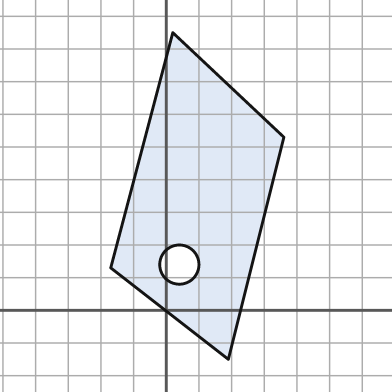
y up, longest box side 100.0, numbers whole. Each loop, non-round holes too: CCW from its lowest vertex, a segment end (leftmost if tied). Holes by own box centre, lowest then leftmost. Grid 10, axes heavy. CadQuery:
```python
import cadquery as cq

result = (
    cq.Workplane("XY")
    .moveTo(19.0, -15.0)
    .lineTo(36.0, 53.0)
    .lineTo(2.0, 85.0)
    .lineTo(-17.0, 13.0)
    .close()
    .moveTo(4.0, 14.0)
    .circle(6.0)
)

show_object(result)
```